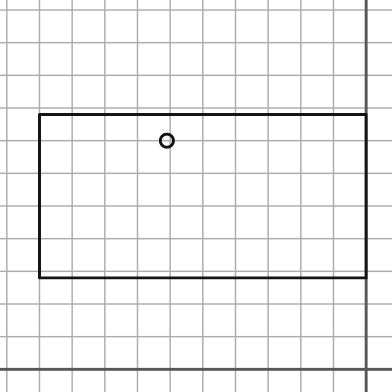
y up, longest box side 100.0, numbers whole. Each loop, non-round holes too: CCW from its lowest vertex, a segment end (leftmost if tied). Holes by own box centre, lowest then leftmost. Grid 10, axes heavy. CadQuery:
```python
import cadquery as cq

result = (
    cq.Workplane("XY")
    .moveTo(-100.0, 28.0)
    .lineTo(0.0, 28.0)
    .lineTo(0.0, 78.0)
    .lineTo(-100.0, 78.0)
    .close()
    .moveTo(-61.0, 70.0)
    .circle(2.0)
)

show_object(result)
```